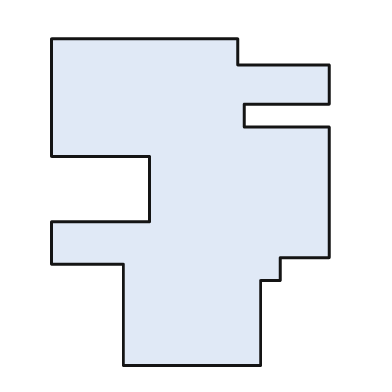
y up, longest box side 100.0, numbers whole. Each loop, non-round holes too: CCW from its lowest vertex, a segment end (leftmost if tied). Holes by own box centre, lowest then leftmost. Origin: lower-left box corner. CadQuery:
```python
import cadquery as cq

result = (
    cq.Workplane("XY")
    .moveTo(22.0, 0.0)
    .lineTo(64.0, 0.0)
    .lineTo(64.0, 26.0)
    .lineTo(70.0, 26.0)
    .lineTo(70.0, 33.0)
    .lineTo(85.0, 33.0)
    .lineTo(85.0, 73.0)
    .lineTo(59.0, 73.0)
    .lineTo(59.0, 80.0)
    .lineTo(85.0, 80.0)
    .lineTo(85.0, 92.0)
    .lineTo(57.0, 92.0)
    .lineTo(57.0, 100.0)
    .lineTo(0.0, 100.0)
    .lineTo(0.0, 64.0)
    .lineTo(30.0, 64.0)
    .lineTo(30.0, 44.0)
    .lineTo(0.0, 44.0)
    .lineTo(0.0, 31.0)
    .lineTo(22.0, 31.0)
    .close()
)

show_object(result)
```